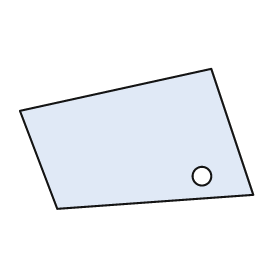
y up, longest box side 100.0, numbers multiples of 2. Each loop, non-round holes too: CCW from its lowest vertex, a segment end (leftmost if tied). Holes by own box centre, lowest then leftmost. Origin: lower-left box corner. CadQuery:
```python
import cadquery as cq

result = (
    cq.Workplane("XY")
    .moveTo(16.0, 0.0)
    .lineTo(100.0, 6.0)
    .lineTo(82.0, 60.0)
    .lineTo(0.0, 42.0)
    .close()
    .moveTo(78.0, 14.0)
    .circle(4.0)
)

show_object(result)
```